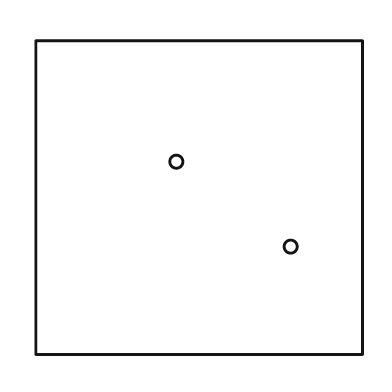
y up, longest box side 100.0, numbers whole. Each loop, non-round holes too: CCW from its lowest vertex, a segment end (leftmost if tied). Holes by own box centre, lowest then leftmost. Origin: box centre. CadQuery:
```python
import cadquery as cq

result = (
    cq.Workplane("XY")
    .moveTo(-50.0, -48.0)
    .lineTo(50.0, -48.0)
    .lineTo(50.0, 48.0)
    .lineTo(-50.0, 48.0)
    .close()
    .moveTo(28.0, -15.0)
    .circle(2.0)
    .moveTo(-7.0, 11.0)
    .circle(2.0)
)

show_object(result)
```